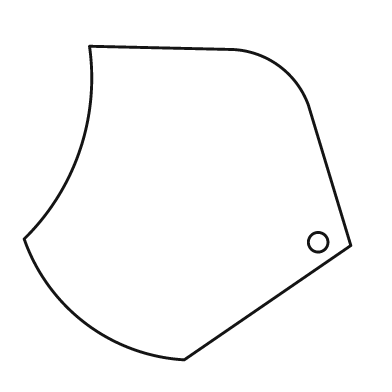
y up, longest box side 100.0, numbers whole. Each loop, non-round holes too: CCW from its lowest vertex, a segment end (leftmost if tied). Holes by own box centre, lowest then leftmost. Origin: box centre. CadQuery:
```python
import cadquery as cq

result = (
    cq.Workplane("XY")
    .moveTo(-1.0, -48.0)
    .lineTo(50.0, -13.0)
    .lineTo(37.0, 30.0)
    .threePointArc((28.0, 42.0), (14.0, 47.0))
    .lineTo(-30.0, 48.0)
    .threePointArc((-33.0, 16.0), (-50.0, -11.0))
    .threePointArc((-31.0, -37.0), (-1.0, -48.0))
    .close()
    .moveTo(40.0, -12.0)
    .circle(3.0)
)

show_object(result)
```